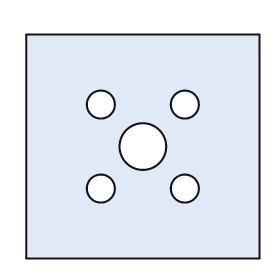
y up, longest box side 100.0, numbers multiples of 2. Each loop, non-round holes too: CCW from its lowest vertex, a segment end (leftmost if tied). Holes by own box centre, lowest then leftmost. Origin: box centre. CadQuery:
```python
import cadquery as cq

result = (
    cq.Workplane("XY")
    .moveTo(-50.0, -48.0)
    .lineTo(50.0, -48.0)
    .lineTo(50.0, 48.0)
    .lineTo(-50.0, 48.0)
    .close()
    .moveTo(-18.0, -18.0)
    .circle(6.0)
    .moveTo(18.0, -18.0)
    .circle(6.0)
    .moveTo(0.0, 0.0)
    .circle(10.0)
    .moveTo(-18.0, 18.0)
    .circle(6.0)
    .moveTo(18.0, 18.0)
    .circle(6.0)
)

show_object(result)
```